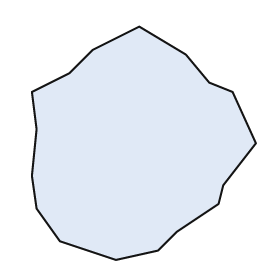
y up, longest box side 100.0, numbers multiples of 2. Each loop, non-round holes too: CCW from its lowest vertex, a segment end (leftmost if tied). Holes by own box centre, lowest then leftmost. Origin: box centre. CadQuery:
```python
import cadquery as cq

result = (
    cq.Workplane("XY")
    .moveTo(-12.0, -50.0)
    .lineTo(6.0, -46.0)
    .lineTo(14.0, -38.0)
    .lineTo(32.0, -26.0)
    .lineTo(34.0, -18.0)
    .lineTo(48.0, 0.0)
    .lineTo(38.0, 22.0)
    .lineTo(28.0, 26.0)
    .lineTo(18.0, 38.0)
    .lineTo(-2.0, 50.0)
    .lineTo(-22.0, 40.0)
    .lineTo(-32.0, 30.0)
    .lineTo(-48.0, 22.0)
    .lineTo(-46.0, 6.0)
    .lineTo(-48.0, -14.0)
    .lineTo(-46.0, -28.0)
    .lineTo(-36.0, -42.0)
    .close()
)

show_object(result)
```